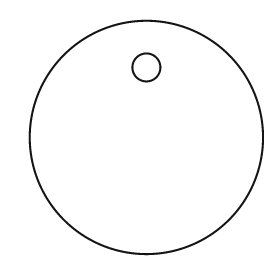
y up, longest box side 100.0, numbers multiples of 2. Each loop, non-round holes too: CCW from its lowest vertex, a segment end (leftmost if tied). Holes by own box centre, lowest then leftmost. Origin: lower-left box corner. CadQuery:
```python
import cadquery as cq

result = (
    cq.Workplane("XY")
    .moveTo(50.0, 50.0)
    .circle(50.0)
    .moveTo(50.0, 80.0)
    .circle(6.0)
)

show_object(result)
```